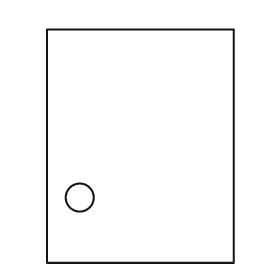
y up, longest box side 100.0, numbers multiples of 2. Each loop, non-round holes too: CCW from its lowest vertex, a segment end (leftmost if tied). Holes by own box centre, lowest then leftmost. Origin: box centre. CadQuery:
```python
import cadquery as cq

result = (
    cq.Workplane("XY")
    .moveTo(-40.0, -50.0)
    .lineTo(40.0, -50.0)
    .lineTo(40.0, 50.0)
    .lineTo(-40.0, 50.0)
    .close()
    .moveTo(-26.0, -22.0)
    .circle(6.0)
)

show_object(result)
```